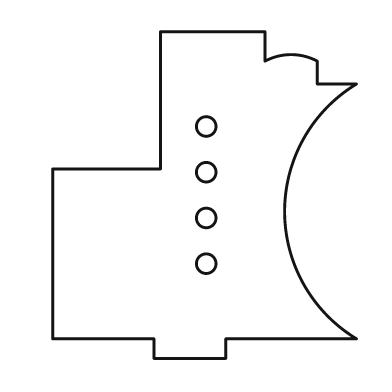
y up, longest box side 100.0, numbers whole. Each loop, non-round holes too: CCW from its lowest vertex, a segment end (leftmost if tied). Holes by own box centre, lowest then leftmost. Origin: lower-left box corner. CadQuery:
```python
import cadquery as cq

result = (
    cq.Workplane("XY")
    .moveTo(31.0, 0.0)
    .lineTo(53.0, 0.0)
    .lineTo(53.0, 6.0)
    .lineTo(93.0, 6.0)
    .threePointArc((71.0, 45.0), (93.0, 84.0))
    .lineTo(81.0, 84.0)
    .lineTo(81.0, 91.0)
    .threePointArc((73.0, 93.0), (65.0, 91.0))
    .lineTo(65.0, 100.0)
    .lineTo(33.0, 100.0)
    .lineTo(33.0, 58.0)
    .lineTo(0.0, 58.0)
    .lineTo(0.0, 6.0)
    .lineTo(31.0, 6.0)
    .close()
    .moveTo(47.0, 29.0)
    .circle(3.0)
    .moveTo(47.0, 43.0)
    .circle(3.0)
    .moveTo(47.0, 57.0)
    .circle(3.0)
    .moveTo(47.0, 71.0)
    .circle(3.0)
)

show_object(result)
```